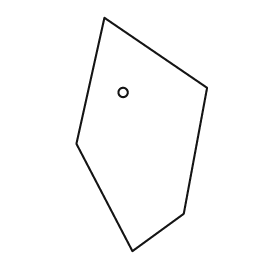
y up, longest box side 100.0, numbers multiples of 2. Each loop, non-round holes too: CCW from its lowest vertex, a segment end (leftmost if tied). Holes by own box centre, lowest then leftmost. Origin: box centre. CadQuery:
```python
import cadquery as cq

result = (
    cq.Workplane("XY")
    .moveTo(-4.0, -50.0)
    .lineTo(18.0, -34.0)
    .lineTo(28.0, 20.0)
    .lineTo(-16.0, 50.0)
    .lineTo(-28.0, -4.0)
    .close()
    .moveTo(-8.0, 18.0)
    .circle(2.0)
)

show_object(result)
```